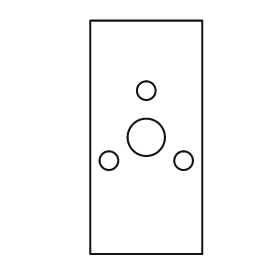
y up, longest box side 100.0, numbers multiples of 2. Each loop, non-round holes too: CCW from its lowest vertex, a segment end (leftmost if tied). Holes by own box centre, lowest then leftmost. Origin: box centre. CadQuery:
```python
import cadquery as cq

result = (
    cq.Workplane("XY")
    .moveTo(-24.0, -50.0)
    .lineTo(24.0, -50.0)
    .lineTo(24.0, 50.0)
    .lineTo(-24.0, 50.0)
    .close()
    .moveTo(-16.0, -10.0)
    .circle(4.0)
    .moveTo(16.0, -10.0)
    .circle(4.0)
    .moveTo(0.0, 0.0)
    .circle(8.0)
    .moveTo(0.0, 20.0)
    .circle(4.0)
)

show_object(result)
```